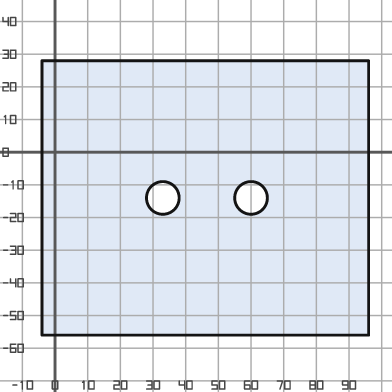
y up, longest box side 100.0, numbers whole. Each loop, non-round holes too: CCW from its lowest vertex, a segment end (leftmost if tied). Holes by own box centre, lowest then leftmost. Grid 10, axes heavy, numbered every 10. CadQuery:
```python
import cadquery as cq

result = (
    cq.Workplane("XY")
    .moveTo(-4.0, -56.0)
    .lineTo(96.0, -56.0)
    .lineTo(96.0, 28.0)
    .lineTo(-4.0, 28.0)
    .close()
    .moveTo(33.0, -14.0)
    .circle(5.0)
    .moveTo(60.0, -14.0)
    .circle(5.0)
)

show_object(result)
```